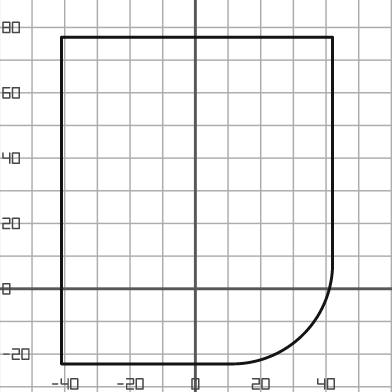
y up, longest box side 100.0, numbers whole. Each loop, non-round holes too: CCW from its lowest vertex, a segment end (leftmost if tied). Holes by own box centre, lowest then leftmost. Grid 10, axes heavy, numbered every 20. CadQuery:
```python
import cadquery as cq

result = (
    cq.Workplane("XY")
    .moveTo(-41.0, -23.0)
    .lineTo(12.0, -23.0)
    .threePointArc((33.0, -14.0), (42.0, 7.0))
    .lineTo(42.0, 77.0)
    .lineTo(-41.0, 77.0)
    .close()
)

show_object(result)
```